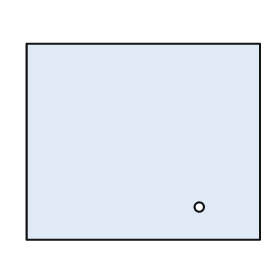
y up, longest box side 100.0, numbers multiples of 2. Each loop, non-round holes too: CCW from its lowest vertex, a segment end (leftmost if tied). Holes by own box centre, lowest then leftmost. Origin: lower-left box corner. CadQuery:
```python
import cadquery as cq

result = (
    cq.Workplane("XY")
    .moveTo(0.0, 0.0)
    .lineTo(100.0, 0.0)
    .lineTo(100.0, 84.0)
    .lineTo(0.0, 84.0)
    .close()
    .moveTo(74.0, 14.0)
    .circle(2.0)
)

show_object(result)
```